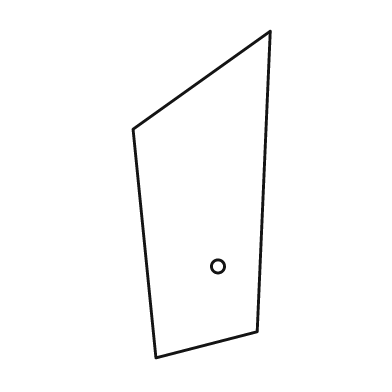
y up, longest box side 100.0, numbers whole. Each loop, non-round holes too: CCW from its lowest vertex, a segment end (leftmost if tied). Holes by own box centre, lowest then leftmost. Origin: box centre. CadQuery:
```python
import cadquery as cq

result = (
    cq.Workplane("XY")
    .moveTo(-14.0, -50.0)
    .lineTo(17.0, -42.0)
    .lineTo(21.0, 50.0)
    .lineTo(-21.0, 20.0)
    .close()
    .moveTo(5.0, -22.0)
    .circle(2.0)
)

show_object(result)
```